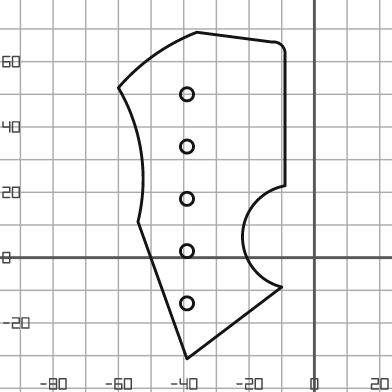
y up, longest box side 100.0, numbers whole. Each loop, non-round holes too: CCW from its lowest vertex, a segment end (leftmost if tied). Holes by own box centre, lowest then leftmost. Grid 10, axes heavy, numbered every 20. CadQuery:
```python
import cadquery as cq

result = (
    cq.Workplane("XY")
    .moveTo(-39.0, -31.0)
    .lineTo(-10.0, -9.0)
    .threePointArc((-22.0, 7.0), (-9.0, 22.0))
    .lineTo(-9.0, 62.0)
    .threePointArc((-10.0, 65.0), (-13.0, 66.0))
    .lineTo(-36.0, 69.0)
    .threePointArc((-49.0, 62.0), (-60.0, 52.0))
    .threePointArc((-53.0, 32.0), (-54.0, 11.0))
    .close()
    .moveTo(-39.0, -14.0)
    .circle(2.0)
    .moveTo(-39.0, 2.0)
    .circle(2.0)
    .moveTo(-39.0, 18.0)
    .circle(2.0)
    .moveTo(-39.0, 34.0)
    .circle(2.0)
    .moveTo(-39.0, 50.0)
    .circle(2.0)
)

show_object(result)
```